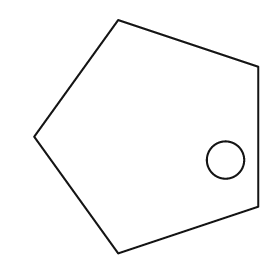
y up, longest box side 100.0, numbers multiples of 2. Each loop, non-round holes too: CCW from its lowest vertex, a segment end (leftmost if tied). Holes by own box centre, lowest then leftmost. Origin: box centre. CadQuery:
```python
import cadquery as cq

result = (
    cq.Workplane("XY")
    .moveTo(-12.0, -50.0)
    .lineTo(48.0, -30.0)
    .lineTo(48.0, 30.0)
    .lineTo(-12.0, 50.0)
    .lineTo(-48.0, 0.0)
    .close()
    .moveTo(34.0, -10.0)
    .circle(8.0)
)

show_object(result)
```